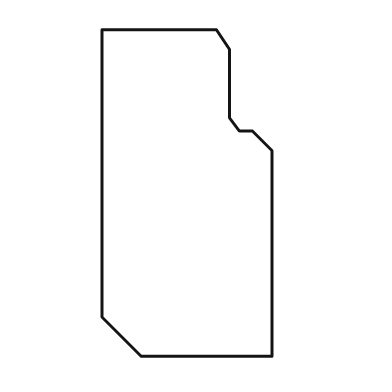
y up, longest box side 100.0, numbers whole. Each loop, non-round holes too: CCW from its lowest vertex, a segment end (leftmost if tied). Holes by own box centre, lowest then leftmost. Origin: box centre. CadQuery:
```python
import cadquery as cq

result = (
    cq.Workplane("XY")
    .moveTo(-14.0, -50.0)
    .lineTo(26.0, -50.0)
    .lineTo(26.0, 13.0)
    .lineTo(20.0, 19.0)
    .lineTo(16.0, 19.0)
    .lineTo(13.0, 23.0)
    .lineTo(13.0, 44.0)
    .lineTo(9.0, 50.0)
    .lineTo(-26.0, 50.0)
    .lineTo(-26.0, -38.0)
    .close()
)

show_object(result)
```